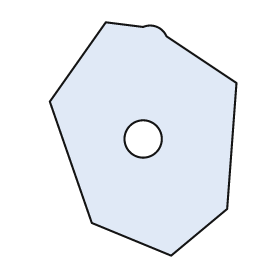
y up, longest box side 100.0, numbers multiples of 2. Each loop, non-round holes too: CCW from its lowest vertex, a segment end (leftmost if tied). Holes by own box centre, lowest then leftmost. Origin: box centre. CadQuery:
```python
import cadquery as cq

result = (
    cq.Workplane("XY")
    .moveTo(12.0, -50.0)
    .lineTo(36.0, -30.0)
    .lineTo(40.0, 24.0)
    .lineTo(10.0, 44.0)
    .threePointArc((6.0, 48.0), (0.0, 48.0))
    .lineTo(-16.0, 50.0)
    .lineTo(-40.0, 16.0)
    .lineTo(-22.0, -36.0)
    .close()
    .moveTo(0.0, 0.0)
    .circle(8.0)
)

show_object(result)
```